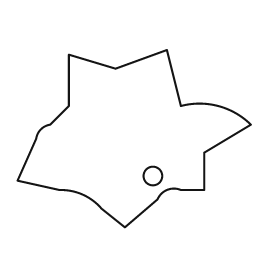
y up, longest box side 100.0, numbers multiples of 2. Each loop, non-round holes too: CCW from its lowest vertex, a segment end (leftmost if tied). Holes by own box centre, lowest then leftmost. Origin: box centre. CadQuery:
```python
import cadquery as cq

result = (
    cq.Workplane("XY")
    .moveTo(-4.0, -38.0)
    .lineTo(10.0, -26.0)
    .threePointArc((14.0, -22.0), (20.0, -22.0))
    .lineTo(30.0, -22.0)
    .lineTo(30.0, -6.0)
    .lineTo(50.0, 6.0)
    .threePointArc((36.0, 14.0), (20.0, 14.0))
    .lineTo(14.0, 38.0)
    .lineTo(-8.0, 30.0)
    .lineTo(-28.0, 36.0)
    .lineTo(-28.0, 14.0)
    .lineTo(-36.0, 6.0)
    .threePointArc((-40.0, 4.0), (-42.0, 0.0))
    .lineTo(-50.0, -18.0)
    .lineTo(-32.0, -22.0)
    .threePointArc((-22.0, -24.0), (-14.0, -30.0))
    .close()
    .moveTo(8.0, -16.0)
    .circle(4.0)
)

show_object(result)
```